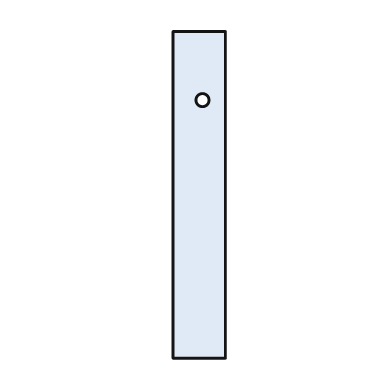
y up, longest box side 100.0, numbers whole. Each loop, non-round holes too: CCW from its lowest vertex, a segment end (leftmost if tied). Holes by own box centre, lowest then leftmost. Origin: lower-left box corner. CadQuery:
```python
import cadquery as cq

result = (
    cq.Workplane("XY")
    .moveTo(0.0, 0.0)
    .lineTo(16.0, 0.0)
    .lineTo(16.0, 100.0)
    .lineTo(0.0, 100.0)
    .close()
    .moveTo(9.0, 79.0)
    .circle(2.0)
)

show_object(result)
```